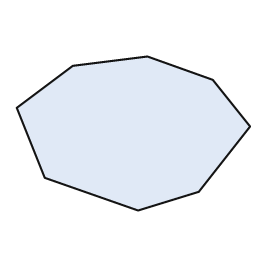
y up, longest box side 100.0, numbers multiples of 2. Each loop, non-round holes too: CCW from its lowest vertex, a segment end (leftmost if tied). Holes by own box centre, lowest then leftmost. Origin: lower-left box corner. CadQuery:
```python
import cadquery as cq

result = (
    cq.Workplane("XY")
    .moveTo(52.0, 0.0)
    .lineTo(78.0, 8.0)
    .lineTo(100.0, 36.0)
    .lineTo(84.0, 56.0)
    .lineTo(56.0, 66.0)
    .lineTo(24.0, 62.0)
    .lineTo(0.0, 44.0)
    .lineTo(12.0, 14.0)
    .close()
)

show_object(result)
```